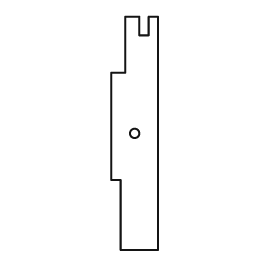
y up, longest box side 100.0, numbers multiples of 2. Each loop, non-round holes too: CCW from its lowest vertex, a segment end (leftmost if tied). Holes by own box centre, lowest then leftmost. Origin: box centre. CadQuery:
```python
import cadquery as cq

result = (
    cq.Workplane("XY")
    .moveTo(-6.0, -50.0)
    .lineTo(10.0, -50.0)
    .lineTo(10.0, 50.0)
    .lineTo(6.0, 50.0)
    .lineTo(6.0, 42.0)
    .lineTo(2.0, 42.0)
    .lineTo(2.0, 50.0)
    .lineTo(-4.0, 50.0)
    .lineTo(-4.0, 26.0)
    .lineTo(-10.0, 26.0)
    .lineTo(-10.0, -20.0)
    .lineTo(-6.0, -20.0)
    .close()
    .moveTo(0.0, 0.0)
    .circle(2.0)
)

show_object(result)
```